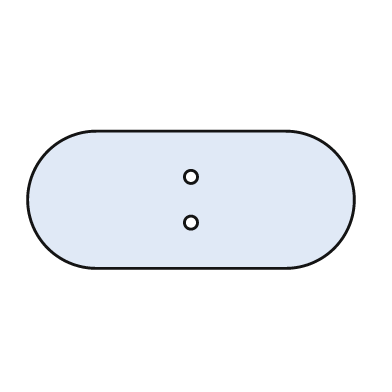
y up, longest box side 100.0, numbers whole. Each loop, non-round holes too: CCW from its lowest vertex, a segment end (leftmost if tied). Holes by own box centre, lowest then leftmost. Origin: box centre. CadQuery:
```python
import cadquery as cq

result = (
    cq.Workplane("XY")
    .moveTo(-29.0, -21.0)
    .lineTo(29.0, -21.0)
    .threePointArc((50.0, 0.0), (29.0, 21.0))
    .lineTo(-29.0, 21.0)
    .threePointArc((-50.0, 0.0), (-29.0, -21.0))
    .close()
    .moveTo(0.0, -7.0)
    .circle(2.0)
    .moveTo(0.0, 7.0)
    .circle(2.0)
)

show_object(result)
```